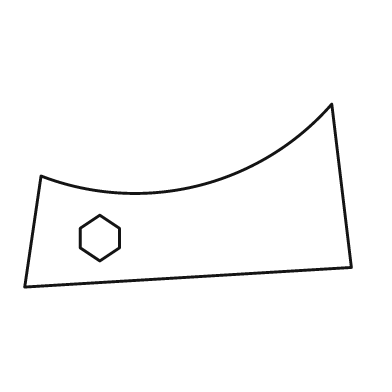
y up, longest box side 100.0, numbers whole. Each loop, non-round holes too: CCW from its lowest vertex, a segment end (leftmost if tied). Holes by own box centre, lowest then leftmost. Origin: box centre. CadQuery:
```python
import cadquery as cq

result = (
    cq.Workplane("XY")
    .moveTo(-50.0, -28.0)
    .lineTo(50.0, -22.0)
    .lineTo(44.0, 28.0)
    .threePointArc((3.0, 3.0), (-45.0, 6.0))
    .close()
    .moveTo(-27.0, -20.0)
    .lineTo(-21.0, -16.0)
    .lineTo(-21.0, -10.0)
    .lineTo(-27.0, -6.0)
    .lineTo(-33.0, -10.0)
    .lineTo(-33.0, -16.0)
    .close()
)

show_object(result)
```